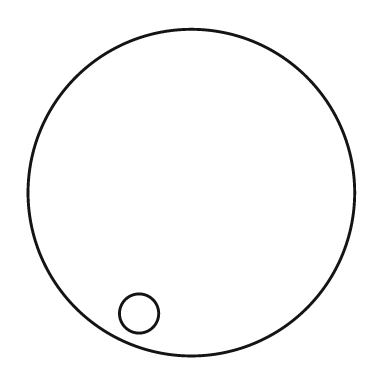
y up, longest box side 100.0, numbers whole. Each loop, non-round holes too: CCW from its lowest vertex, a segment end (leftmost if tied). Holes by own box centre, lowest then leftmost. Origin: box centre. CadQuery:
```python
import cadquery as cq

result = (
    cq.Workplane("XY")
    .moveTo(0.0, 0.0)
    .circle(50.0)
    .moveTo(-16.0, -37.0)
    .circle(6.0)
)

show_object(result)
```